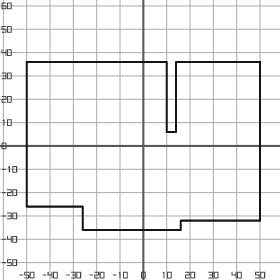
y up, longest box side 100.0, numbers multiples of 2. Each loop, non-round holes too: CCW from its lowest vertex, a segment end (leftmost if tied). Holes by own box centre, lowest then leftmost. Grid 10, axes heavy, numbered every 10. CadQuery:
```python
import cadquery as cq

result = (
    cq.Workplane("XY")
    .moveTo(-26.0, -36.0)
    .lineTo(16.0, -36.0)
    .lineTo(16.0, -32.0)
    .lineTo(50.0, -32.0)
    .lineTo(50.0, 36.0)
    .lineTo(14.0, 36.0)
    .lineTo(14.0, 6.0)
    .lineTo(10.0, 6.0)
    .lineTo(10.0, 36.0)
    .lineTo(-50.0, 36.0)
    .lineTo(-50.0, -26.0)
    .lineTo(-26.0, -26.0)
    .close()
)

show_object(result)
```